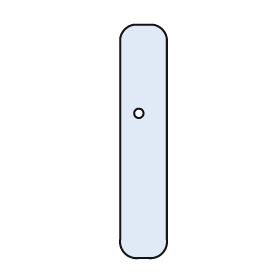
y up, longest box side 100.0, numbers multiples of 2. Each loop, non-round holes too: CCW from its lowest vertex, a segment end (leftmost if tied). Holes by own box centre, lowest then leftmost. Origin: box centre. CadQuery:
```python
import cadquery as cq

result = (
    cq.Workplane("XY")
    .moveTo(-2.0, -50.0)
    .lineTo(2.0, -50.0)
    .threePointArc((8.0, -48.0), (10.0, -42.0))
    .lineTo(10.0, 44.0)
    .threePointArc((8.0, 48.0), (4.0, 50.0))
    .lineTo(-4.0, 50.0)
    .threePointArc((-8.0, 48.0), (-10.0, 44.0))
    .lineTo(-10.0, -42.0)
    .threePointArc((-8.0, -48.0), (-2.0, -50.0))
    .close()
    .moveTo(-2.0, 12.0)
    .circle(2.0)
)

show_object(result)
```